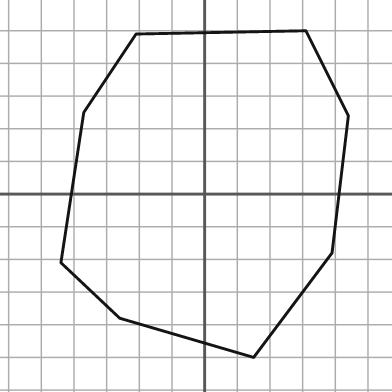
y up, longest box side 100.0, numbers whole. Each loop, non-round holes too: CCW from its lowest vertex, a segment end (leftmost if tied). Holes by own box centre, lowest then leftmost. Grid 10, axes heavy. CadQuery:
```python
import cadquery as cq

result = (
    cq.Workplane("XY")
    .moveTo(15.0, -50.0)
    .lineTo(39.0, -18.0)
    .lineTo(44.0, 24.0)
    .lineTo(31.0, 50.0)
    .lineTo(-21.0, 49.0)
    .lineTo(-37.0, 25.0)
    .lineTo(-44.0, -21.0)
    .lineTo(-26.0, -38.0)
    .close()
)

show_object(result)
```